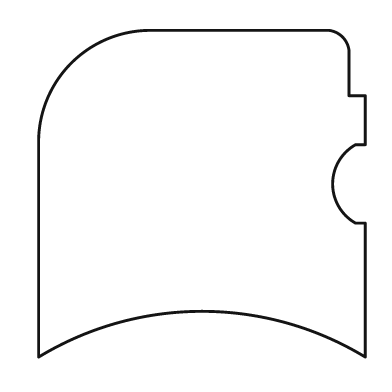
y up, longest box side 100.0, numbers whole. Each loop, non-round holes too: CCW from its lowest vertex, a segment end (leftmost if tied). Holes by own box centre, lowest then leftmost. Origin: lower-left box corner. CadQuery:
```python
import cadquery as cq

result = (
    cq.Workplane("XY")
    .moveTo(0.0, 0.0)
    .threePointArc((50.0, 14.0), (100.0, 0.0))
    .lineTo(100.0, 41.0)
    .lineTo(97.0, 41.0)
    .threePointArc((90.0, 53.0), (97.0, 65.0))
    .lineTo(100.0, 65.0)
    .lineTo(100.0, 80.0)
    .lineTo(95.0, 80.0)
    .lineTo(95.0, 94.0)
    .threePointArc((93.0, 98.0), (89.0, 100.0))
    .lineTo(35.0, 100.0)
    .threePointArc((10.0, 90.0), (0.0, 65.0))
    .close()
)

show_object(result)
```